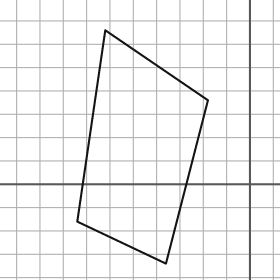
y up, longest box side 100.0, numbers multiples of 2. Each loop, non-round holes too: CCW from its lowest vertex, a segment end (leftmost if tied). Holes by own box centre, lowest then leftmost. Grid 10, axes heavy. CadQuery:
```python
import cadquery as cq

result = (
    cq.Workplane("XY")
    .moveTo(-36.0, -34.0)
    .lineTo(-18.0, 36.0)
    .lineTo(-62.0, 66.0)
    .lineTo(-74.0, -16.0)
    .close()
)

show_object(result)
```